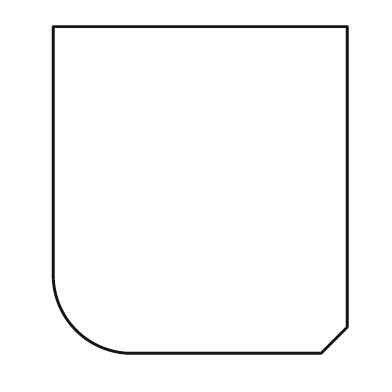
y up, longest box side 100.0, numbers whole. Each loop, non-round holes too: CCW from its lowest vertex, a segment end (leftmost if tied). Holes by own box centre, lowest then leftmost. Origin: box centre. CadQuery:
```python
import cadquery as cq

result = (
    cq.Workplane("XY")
    .moveTo(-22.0, -50.0)
    .lineTo(37.0, -50.0)
    .lineTo(45.0, -42.0)
    .lineTo(45.0, 50.0)
    .lineTo(-45.0, 50.0)
    .lineTo(-45.0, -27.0)
    .threePointArc((-38.0, -43.0), (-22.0, -50.0))
    .close()
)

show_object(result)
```